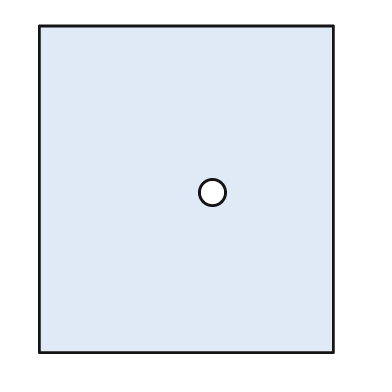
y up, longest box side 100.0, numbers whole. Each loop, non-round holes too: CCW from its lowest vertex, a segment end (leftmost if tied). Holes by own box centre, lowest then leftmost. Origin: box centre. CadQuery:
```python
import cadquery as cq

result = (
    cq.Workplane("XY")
    .moveTo(-45.0, -50.0)
    .lineTo(45.0, -50.0)
    .lineTo(45.0, 50.0)
    .lineTo(-45.0, 50.0)
    .close()
    .moveTo(8.0, -1.0)
    .circle(4.0)
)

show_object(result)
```